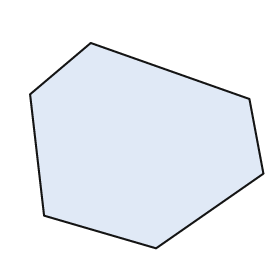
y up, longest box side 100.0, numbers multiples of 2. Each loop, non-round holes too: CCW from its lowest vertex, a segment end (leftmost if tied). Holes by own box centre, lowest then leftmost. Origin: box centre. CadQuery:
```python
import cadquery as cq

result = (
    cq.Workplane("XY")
    .moveTo(4.0, -44.0)
    .lineTo(50.0, -12.0)
    .lineTo(44.0, 20.0)
    .lineTo(-24.0, 44.0)
    .lineTo(-50.0, 22.0)
    .lineTo(-44.0, -30.0)
    .close()
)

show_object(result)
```